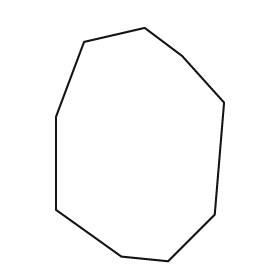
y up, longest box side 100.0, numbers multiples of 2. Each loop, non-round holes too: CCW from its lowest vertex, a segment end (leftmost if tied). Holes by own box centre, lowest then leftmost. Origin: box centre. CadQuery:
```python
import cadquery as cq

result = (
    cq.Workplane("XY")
    .moveTo(12.0, -50.0)
    .lineTo(32.0, -30.0)
    .lineTo(36.0, 18.0)
    .lineTo(18.0, 38.0)
    .lineTo(2.0, 50.0)
    .lineTo(-24.0, 44.0)
    .lineTo(-36.0, 12.0)
    .lineTo(-36.0, -28.0)
    .lineTo(-8.0, -48.0)
    .close()
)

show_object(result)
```